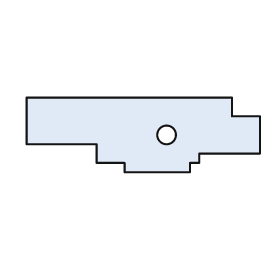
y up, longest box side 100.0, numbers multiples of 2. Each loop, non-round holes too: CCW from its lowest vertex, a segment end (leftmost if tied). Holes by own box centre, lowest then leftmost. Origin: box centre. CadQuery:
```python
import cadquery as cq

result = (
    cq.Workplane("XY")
    .moveTo(-8.0, -16.0)
    .lineTo(20.0, -16.0)
    .lineTo(20.0, -12.0)
    .lineTo(24.0, -12.0)
    .lineTo(24.0, -8.0)
    .lineTo(50.0, -8.0)
    .lineTo(50.0, 8.0)
    .lineTo(38.0, 8.0)
    .lineTo(38.0, 16.0)
    .lineTo(-50.0, 16.0)
    .lineTo(-50.0, -4.0)
    .lineTo(-20.0, -4.0)
    .lineTo(-20.0, -12.0)
    .lineTo(-8.0, -12.0)
    .close()
    .moveTo(10.0, 0.0)
    .circle(4.0)
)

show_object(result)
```